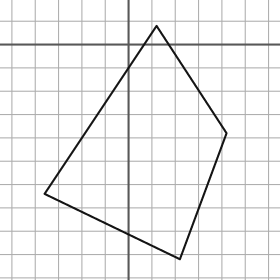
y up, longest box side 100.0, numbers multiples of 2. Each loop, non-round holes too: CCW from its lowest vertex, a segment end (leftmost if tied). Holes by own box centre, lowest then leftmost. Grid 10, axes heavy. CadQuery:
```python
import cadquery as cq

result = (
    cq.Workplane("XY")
    .moveTo(22.0, -92.0)
    .lineTo(42.0, -38.0)
    .lineTo(12.0, 8.0)
    .lineTo(-36.0, -64.0)
    .close()
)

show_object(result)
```